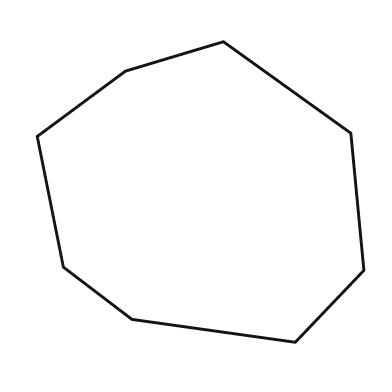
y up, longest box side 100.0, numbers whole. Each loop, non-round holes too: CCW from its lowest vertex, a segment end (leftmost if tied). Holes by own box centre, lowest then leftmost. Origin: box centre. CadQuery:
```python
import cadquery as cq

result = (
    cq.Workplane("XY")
    .moveTo(29.0, -46.0)
    .lineTo(50.0, -24.0)
    .lineTo(46.0, 18.0)
    .lineTo(7.0, 46.0)
    .lineTo(-23.0, 37.0)
    .lineTo(-50.0, 17.0)
    .lineTo(-42.0, -23.0)
    .lineTo(-21.0, -39.0)
    .close()
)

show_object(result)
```